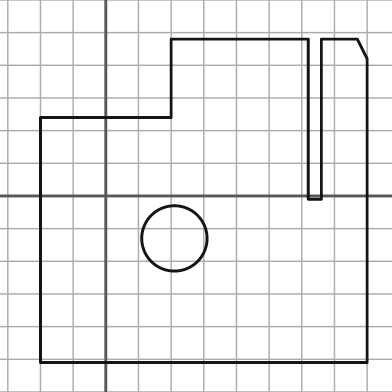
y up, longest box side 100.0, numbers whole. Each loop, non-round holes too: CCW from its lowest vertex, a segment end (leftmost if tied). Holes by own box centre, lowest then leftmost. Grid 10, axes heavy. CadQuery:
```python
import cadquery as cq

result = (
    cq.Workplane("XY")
    .moveTo(-20.0, -51.0)
    .lineTo(80.0, -51.0)
    .lineTo(80.0, 42.0)
    .lineTo(77.0, 48.0)
    .lineTo(66.0, 48.0)
    .lineTo(66.0, -1.0)
    .lineTo(62.0, -1.0)
    .lineTo(62.0, 48.0)
    .lineTo(20.0, 48.0)
    .lineTo(20.0, 24.0)
    .lineTo(-20.0, 24.0)
    .close()
    .moveTo(21.0, -13.0)
    .circle(10.0)
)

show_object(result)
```